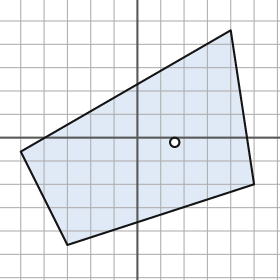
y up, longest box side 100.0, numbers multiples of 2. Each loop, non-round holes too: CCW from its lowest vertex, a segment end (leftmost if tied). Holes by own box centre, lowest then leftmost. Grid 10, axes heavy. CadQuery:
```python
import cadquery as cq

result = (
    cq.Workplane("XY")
    .moveTo(-30.0, -46.0)
    .lineTo(50.0, -20.0)
    .lineTo(40.0, 46.0)
    .lineTo(-50.0, -6.0)
    .close()
    .moveTo(16.0, -2.0)
    .circle(2.0)
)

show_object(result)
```